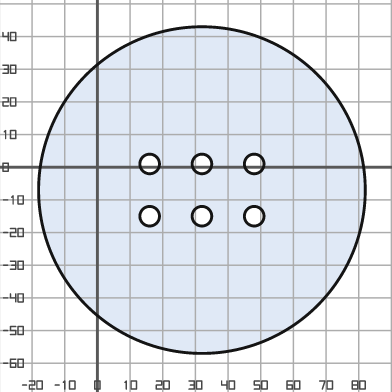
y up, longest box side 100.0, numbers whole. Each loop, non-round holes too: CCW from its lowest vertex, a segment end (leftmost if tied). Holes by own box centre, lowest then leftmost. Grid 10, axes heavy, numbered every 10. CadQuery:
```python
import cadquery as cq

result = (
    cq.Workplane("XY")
    .moveTo(32.0, -7.0)
    .circle(50.0)
    .moveTo(16.0, -15.0)
    .circle(3.0)
    .moveTo(32.0, -15.0)
    .circle(3.0)
    .moveTo(48.0, -15.0)
    .circle(3.0)
    .moveTo(16.0, 1.0)
    .circle(3.0)
    .moveTo(32.0, 1.0)
    .circle(3.0)
    .moveTo(48.0, 1.0)
    .circle(3.0)
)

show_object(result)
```